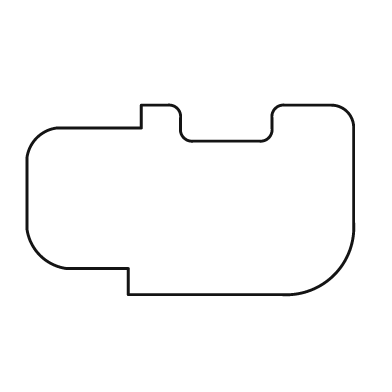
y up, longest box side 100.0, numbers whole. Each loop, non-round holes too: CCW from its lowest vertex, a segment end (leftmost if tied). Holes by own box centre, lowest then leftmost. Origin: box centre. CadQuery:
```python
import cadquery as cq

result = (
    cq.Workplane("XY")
    .moveTo(-19.0, -29.0)
    .lineTo(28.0, -29.0)
    .threePointArc((44.0, -23.0), (50.0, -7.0))
    .lineTo(50.0, 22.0)
    .threePointArc((48.0, 27.0), (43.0, 29.0))
    .lineTo(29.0, 29.0)
    .threePointArc((26.0, 28.0), (25.0, 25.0))
    .lineTo(25.0, 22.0)
    .threePointArc((24.0, 19.0), (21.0, 18.0))
    .lineTo(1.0, 18.0)
    .threePointArc((-2.0, 19.0), (-3.0, 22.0))
    .lineTo(-3.0, 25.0)
    .threePointArc((-4.0, 28.0), (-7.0, 29.0))
    .lineTo(-15.0, 29.0)
    .lineTo(-15.0, 22.0)
    .lineTo(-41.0, 22.0)
    .threePointArc((-47.0, 19.0), (-50.0, 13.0))
    .lineTo(-50.0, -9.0)
    .threePointArc((-46.0, -17.0), (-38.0, -21.0))
    .lineTo(-19.0, -21.0)
    .close()
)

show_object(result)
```